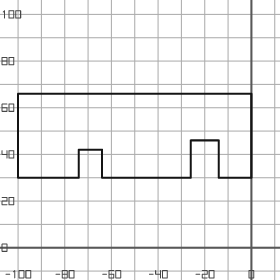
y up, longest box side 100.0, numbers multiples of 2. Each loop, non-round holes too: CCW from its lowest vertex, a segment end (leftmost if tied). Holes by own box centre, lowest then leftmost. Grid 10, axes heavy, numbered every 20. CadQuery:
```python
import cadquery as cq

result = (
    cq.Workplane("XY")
    .moveTo(-100.0, 30.0)
    .lineTo(-74.0, 30.0)
    .lineTo(-74.0, 42.0)
    .lineTo(-64.0, 42.0)
    .lineTo(-64.0, 30.0)
    .lineTo(-26.0, 30.0)
    .lineTo(-26.0, 46.0)
    .lineTo(-14.0, 46.0)
    .lineTo(-14.0, 30.0)
    .lineTo(0.0, 30.0)
    .lineTo(0.0, 66.0)
    .lineTo(-100.0, 66.0)
    .close()
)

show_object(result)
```